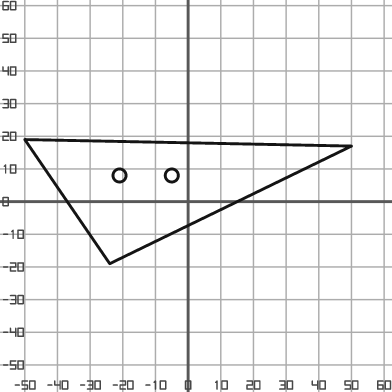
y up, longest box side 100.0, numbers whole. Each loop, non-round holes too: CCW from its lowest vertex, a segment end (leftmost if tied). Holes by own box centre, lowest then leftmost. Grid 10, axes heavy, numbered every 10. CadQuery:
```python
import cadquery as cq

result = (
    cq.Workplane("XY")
    .moveTo(-24.0, -19.0)
    .lineTo(50.0, 17.0)
    .lineTo(-50.0, 19.0)
    .close()
    .moveTo(-21.0, 8.0)
    .circle(2.0)
    .moveTo(-5.0, 8.0)
    .circle(2.0)
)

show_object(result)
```